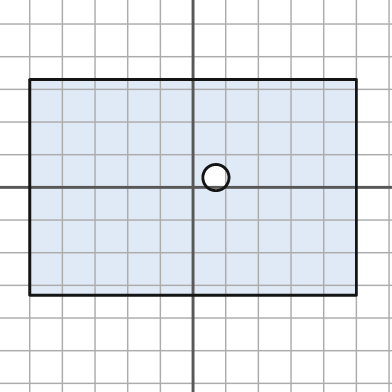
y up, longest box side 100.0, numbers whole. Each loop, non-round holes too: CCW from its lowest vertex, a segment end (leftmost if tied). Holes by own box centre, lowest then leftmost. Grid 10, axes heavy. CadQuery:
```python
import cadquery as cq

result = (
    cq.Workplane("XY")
    .moveTo(-50.0, -33.0)
    .lineTo(50.0, -33.0)
    .lineTo(50.0, 33.0)
    .lineTo(-50.0, 33.0)
    .close()
    .moveTo(7.0, 3.0)
    .circle(4.0)
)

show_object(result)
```